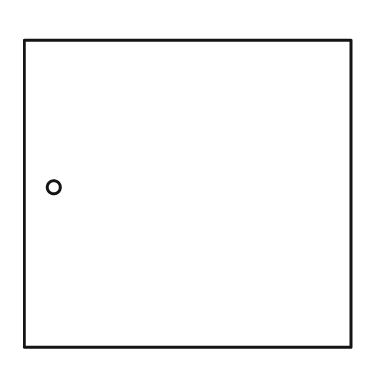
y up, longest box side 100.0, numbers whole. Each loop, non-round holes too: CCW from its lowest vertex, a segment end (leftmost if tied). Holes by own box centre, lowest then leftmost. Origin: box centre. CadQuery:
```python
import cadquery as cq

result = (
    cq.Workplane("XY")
    .moveTo(-50.0, -47.0)
    .lineTo(50.0, -47.0)
    .lineTo(50.0, 47.0)
    .lineTo(-50.0, 47.0)
    .close()
    .moveTo(-41.0, 2.0)
    .circle(2.0)
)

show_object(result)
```